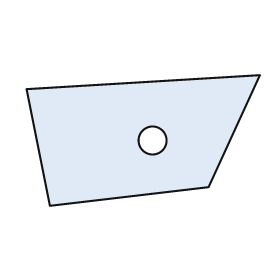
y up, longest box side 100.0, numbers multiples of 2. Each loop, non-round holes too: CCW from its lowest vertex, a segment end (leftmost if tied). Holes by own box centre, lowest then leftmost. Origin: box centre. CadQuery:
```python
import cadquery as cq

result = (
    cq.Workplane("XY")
    .moveTo(-40.0, -28.0)
    .lineTo(28.0, -20.0)
    .lineTo(50.0, 28.0)
    .lineTo(-50.0, 22.0)
    .close()
    .moveTo(4.0, 0.0)
    .circle(6.0)
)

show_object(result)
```